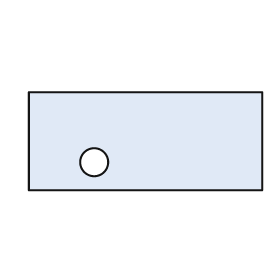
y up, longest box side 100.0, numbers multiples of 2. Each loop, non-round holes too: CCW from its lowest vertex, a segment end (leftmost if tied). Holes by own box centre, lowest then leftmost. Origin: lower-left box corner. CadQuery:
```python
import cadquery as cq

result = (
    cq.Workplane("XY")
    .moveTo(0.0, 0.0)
    .lineTo(100.0, 0.0)
    .lineTo(100.0, 42.0)
    .lineTo(0.0, 42.0)
    .close()
    .moveTo(28.0, 12.0)
    .circle(6.0)
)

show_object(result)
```